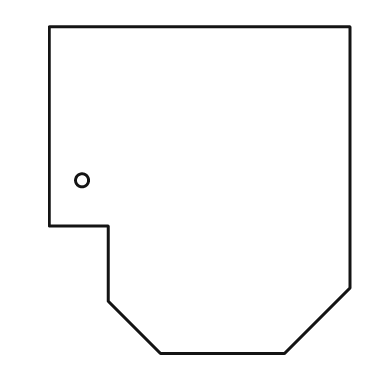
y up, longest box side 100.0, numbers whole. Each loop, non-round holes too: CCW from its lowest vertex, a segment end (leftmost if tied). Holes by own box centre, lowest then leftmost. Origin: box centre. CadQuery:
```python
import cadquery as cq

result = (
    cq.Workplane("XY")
    .moveTo(-12.0, -50.0)
    .lineTo(26.0, -50.0)
    .lineTo(46.0, -30.0)
    .lineTo(46.0, 50.0)
    .lineTo(-46.0, 50.0)
    .lineTo(-46.0, -11.0)
    .lineTo(-28.0, -11.0)
    .lineTo(-28.0, -34.0)
    .close()
    .moveTo(-36.0, 3.0)
    .circle(2.0)
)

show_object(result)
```